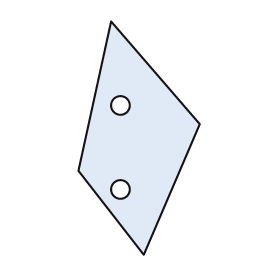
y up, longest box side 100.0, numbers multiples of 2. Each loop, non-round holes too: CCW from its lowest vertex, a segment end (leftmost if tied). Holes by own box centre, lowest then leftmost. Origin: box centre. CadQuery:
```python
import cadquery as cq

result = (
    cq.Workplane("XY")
    .moveTo(2.0, -50.0)
    .lineTo(26.0, 6.0)
    .lineTo(-12.0, 50.0)
    .lineTo(-26.0, -14.0)
    .close()
    .moveTo(-8.0, -22.0)
    .circle(4.0)
    .moveTo(-8.0, 14.0)
    .circle(4.0)
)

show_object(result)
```